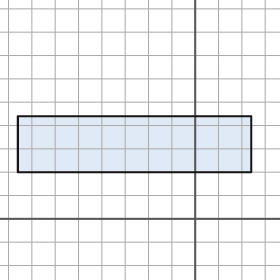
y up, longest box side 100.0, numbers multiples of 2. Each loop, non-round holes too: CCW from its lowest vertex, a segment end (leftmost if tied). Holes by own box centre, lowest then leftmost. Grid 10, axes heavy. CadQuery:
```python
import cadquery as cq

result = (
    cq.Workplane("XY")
    .moveTo(-76.0, 20.0)
    .lineTo(24.0, 20.0)
    .lineTo(24.0, 44.0)
    .lineTo(-76.0, 44.0)
    .close()
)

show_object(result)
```